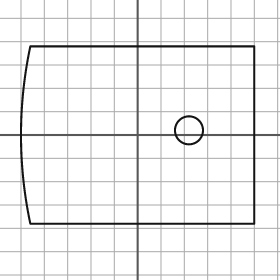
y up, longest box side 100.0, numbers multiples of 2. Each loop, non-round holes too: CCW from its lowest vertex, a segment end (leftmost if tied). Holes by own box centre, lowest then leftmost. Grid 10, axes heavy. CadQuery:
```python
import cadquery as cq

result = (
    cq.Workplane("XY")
    .moveTo(-46.0, -38.0)
    .lineTo(50.0, -38.0)
    .lineTo(50.0, 38.0)
    .lineTo(-46.0, 38.0)
    .threePointArc((-50.0, 0.0), (-46.0, -38.0))
    .close()
    .moveTo(22.0, 2.0)
    .circle(6.0)
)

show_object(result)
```